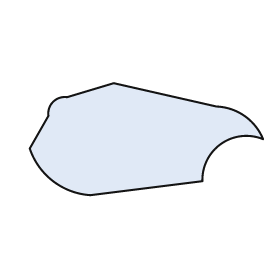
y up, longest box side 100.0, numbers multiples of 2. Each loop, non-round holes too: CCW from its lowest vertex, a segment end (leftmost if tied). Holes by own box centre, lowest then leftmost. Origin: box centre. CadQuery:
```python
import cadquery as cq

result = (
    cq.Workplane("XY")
    .moveTo(-24.0, -24.0)
    .lineTo(24.0, -18.0)
    .threePointArc((32.0, -2.0), (50.0, 0.0))
    .threePointArc((42.0, 10.0), (30.0, 14.0))
    .lineTo(-14.0, 24.0)
    .lineTo(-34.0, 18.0)
    .threePointArc((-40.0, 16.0), (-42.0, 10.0))
    .lineTo(-50.0, -4.0)
    .threePointArc((-40.0, -18.0), (-24.0, -24.0))
    .close()
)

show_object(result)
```